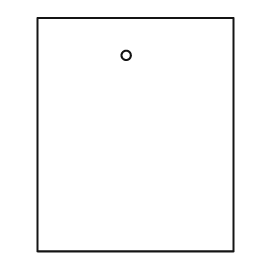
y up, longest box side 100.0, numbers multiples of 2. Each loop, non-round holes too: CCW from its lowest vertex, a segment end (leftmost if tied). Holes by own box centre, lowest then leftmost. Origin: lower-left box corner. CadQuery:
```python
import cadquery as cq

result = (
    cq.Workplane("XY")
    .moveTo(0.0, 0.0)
    .lineTo(84.0, 0.0)
    .lineTo(84.0, 100.0)
    .lineTo(0.0, 100.0)
    .close()
    .moveTo(38.0, 84.0)
    .circle(2.0)
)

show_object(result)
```